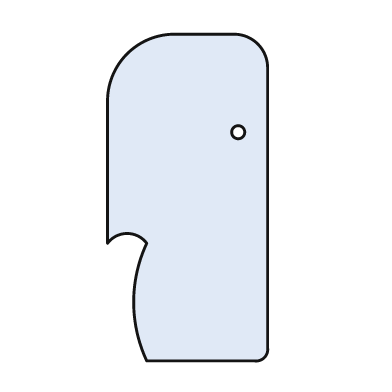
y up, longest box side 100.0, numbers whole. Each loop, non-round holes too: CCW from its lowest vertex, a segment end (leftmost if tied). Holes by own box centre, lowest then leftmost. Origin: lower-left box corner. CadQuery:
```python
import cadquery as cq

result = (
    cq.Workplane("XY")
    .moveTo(12.0, 0.0)
    .lineTo(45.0, 0.0)
    .threePointArc((48.0, 1.0), (49.0, 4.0))
    .lineTo(49.0, 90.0)
    .threePointArc((46.0, 97.0), (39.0, 100.0))
    .lineTo(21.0, 100.0)
    .threePointArc((6.0, 94.0), (0.0, 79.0))
    .lineTo(0.0, 36.0)
    .threePointArc((6.0, 39.0), (12.0, 36.0))
    .threePointArc((8.0, 18.0), (12.0, 0.0))
    .close()
    .moveTo(40.0, 70.0)
    .circle(2.0)
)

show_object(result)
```